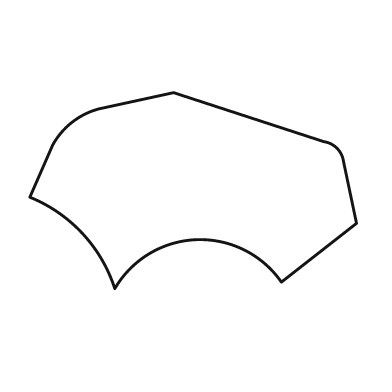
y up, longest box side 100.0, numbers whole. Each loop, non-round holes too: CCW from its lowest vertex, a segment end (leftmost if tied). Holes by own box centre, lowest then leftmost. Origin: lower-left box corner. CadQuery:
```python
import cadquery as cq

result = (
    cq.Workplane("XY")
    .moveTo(26.0, 0.0)
    .threePointArc((51.0, 15.0), (77.0, 2.0))
    .lineTo(100.0, 20.0)
    .lineTo(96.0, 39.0)
    .threePointArc((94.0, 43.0), (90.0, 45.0))
    .lineTo(44.0, 60.0)
    .lineTo(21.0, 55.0)
    .threePointArc((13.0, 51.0), (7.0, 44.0))
    .lineTo(0.0, 28.0)
    .threePointArc((16.0, 17.0), (26.0, 0.0))
    .close()
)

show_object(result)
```